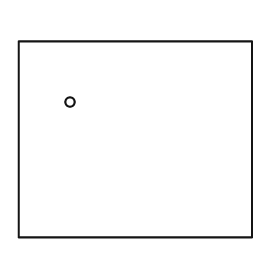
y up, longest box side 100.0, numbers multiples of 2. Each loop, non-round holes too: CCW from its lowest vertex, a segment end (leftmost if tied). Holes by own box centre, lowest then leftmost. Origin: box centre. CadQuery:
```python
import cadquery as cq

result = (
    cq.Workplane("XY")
    .moveTo(-50.0, -42.0)
    .lineTo(50.0, -42.0)
    .lineTo(50.0, 42.0)
    .lineTo(-50.0, 42.0)
    .close()
    .moveTo(-28.0, 16.0)
    .circle(2.0)
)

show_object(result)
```